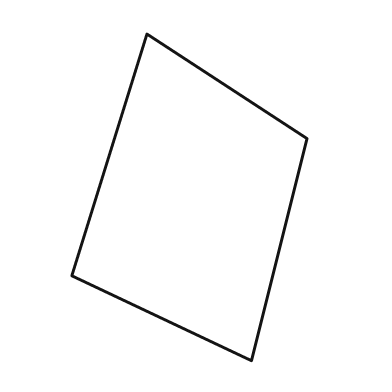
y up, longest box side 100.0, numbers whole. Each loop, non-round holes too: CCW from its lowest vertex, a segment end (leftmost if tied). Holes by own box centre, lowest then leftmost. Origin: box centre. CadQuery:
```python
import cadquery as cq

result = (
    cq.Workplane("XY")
    .moveTo(19.0, -50.0)
    .lineTo(36.0, 18.0)
    .lineTo(-13.0, 50.0)
    .lineTo(-36.0, -24.0)
    .close()
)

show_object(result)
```